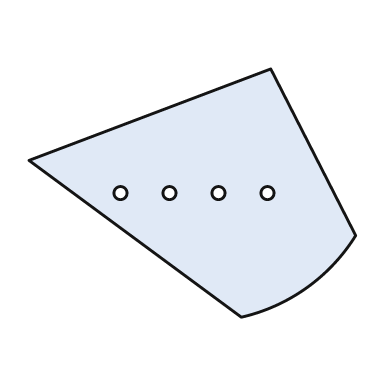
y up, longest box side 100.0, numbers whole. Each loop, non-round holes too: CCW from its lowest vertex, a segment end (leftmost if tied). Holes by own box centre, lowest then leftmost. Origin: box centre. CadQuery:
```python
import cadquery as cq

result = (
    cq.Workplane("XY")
    .moveTo(15.0, -38.0)
    .threePointArc((35.0, -29.0), (50.0, -13.0))
    .lineTo(24.0, 38.0)
    .lineTo(-50.0, 10.0)
    .close()
    .moveTo(-22.0, 0.0)
    .circle(2.0)
    .moveTo(-7.0, 0.0)
    .circle(2.0)
    .moveTo(8.0, 0.0)
    .circle(2.0)
    .moveTo(23.0, 0.0)
    .circle(2.0)
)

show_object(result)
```